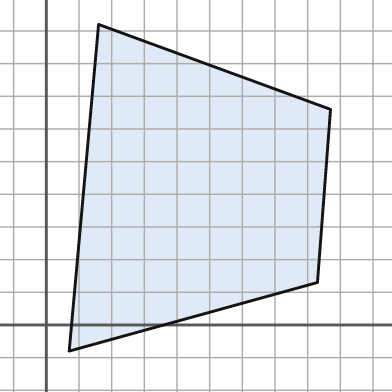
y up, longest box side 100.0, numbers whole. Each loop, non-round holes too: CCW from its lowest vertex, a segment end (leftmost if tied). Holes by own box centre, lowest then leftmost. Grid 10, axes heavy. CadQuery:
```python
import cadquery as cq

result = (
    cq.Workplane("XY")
    .moveTo(7.0, -8.0)
    .lineTo(83.0, 13.0)
    .lineTo(87.0, 66.0)
    .lineTo(16.0, 92.0)
    .close()
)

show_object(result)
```